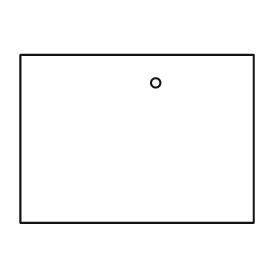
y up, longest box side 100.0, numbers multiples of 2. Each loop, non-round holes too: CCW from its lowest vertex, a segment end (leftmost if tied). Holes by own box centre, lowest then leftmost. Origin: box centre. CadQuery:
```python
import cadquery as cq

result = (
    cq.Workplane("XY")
    .moveTo(-50.0, -36.0)
    .lineTo(50.0, -36.0)
    .lineTo(50.0, 36.0)
    .lineTo(-50.0, 36.0)
    .close()
    .moveTo(8.0, 24.0)
    .circle(2.0)
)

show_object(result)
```